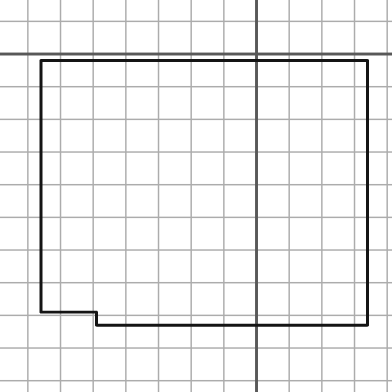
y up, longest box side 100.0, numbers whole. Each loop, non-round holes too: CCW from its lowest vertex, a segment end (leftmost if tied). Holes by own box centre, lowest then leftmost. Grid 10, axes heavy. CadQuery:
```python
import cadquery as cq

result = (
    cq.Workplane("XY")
    .moveTo(-49.0, -83.0)
    .lineTo(34.0, -83.0)
    .lineTo(34.0, -2.0)
    .lineTo(-66.0, -2.0)
    .lineTo(-66.0, -79.0)
    .lineTo(-49.0, -79.0)
    .close()
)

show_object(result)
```